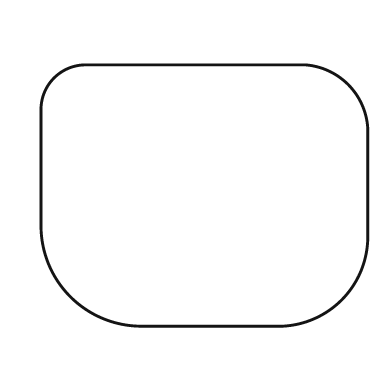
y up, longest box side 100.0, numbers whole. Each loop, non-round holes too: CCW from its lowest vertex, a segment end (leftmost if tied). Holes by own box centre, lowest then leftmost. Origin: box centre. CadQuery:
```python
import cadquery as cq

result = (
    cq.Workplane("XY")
    .moveTo(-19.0, -40.0)
    .lineTo(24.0, -40.0)
    .threePointArc((42.0, -32.0), (50.0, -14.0))
    .lineTo(50.0, 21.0)
    .threePointArc((44.0, 34.0), (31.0, 40.0))
    .lineTo(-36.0, 40.0)
    .threePointArc((-46.0, 36.0), (-50.0, 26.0))
    .lineTo(-50.0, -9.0)
    .threePointArc((-41.0, -31.0), (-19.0, -40.0))
    .close()
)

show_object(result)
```